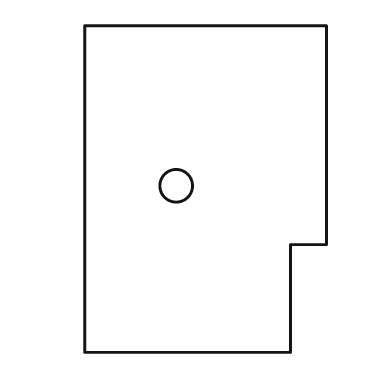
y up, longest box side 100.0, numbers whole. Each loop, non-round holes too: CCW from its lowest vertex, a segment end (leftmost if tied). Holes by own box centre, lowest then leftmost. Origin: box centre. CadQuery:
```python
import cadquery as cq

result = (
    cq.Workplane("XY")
    .moveTo(-37.0, -50.0)
    .lineTo(26.0, -50.0)
    .lineTo(26.0, -17.0)
    .lineTo(37.0, -17.0)
    .lineTo(37.0, 50.0)
    .lineTo(-37.0, 50.0)
    .close()
    .moveTo(-9.0, 1.0)
    .circle(5.0)
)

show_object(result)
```